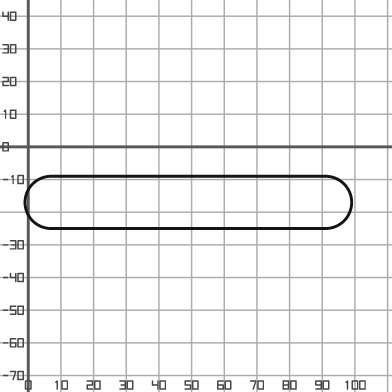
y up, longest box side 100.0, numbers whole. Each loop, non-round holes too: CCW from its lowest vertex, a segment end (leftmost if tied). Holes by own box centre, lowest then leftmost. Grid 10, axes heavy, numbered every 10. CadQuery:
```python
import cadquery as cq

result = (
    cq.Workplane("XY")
    .moveTo(7.0, -25.0)
    .lineTo(91.0, -25.0)
    .threePointArc((99.0, -17.0), (91.0, -9.0))
    .lineTo(7.0, -9.0)
    .threePointArc((-1.0, -17.0), (7.0, -25.0))
    .close()
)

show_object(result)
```